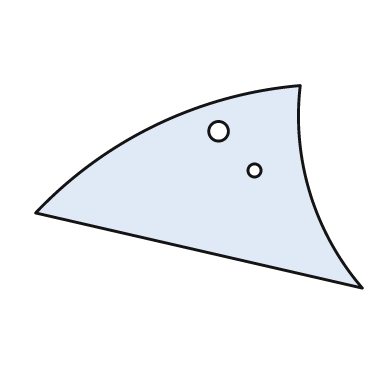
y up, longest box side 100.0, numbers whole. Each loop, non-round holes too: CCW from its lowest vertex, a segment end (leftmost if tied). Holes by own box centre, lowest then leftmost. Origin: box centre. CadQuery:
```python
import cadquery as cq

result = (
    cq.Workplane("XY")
    .moveTo(50.0, -31.0)
    .threePointArc((34.0, -2.0), (31.0, 31.0))
    .threePointArc((-13.0, 19.0), (-50.0, -8.0))
    .close()
    .moveTo(17.0, 5.0)
    .circle(2.0)
    .moveTo(6.0, 17.0)
    .circle(3.0)
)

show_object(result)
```